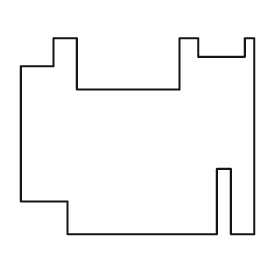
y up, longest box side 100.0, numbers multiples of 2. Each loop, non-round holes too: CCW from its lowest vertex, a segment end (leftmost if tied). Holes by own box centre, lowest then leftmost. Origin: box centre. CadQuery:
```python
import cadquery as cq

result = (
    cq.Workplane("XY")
    .moveTo(-30.0, -42.0)
    .lineTo(34.0, -42.0)
    .lineTo(34.0, -14.0)
    .lineTo(40.0, -14.0)
    .lineTo(40.0, -42.0)
    .lineTo(50.0, -42.0)
    .lineTo(50.0, 42.0)
    .lineTo(46.0, 42.0)
    .lineTo(46.0, 34.0)
    .lineTo(26.0, 34.0)
    .lineTo(26.0, 42.0)
    .lineTo(18.0, 42.0)
    .lineTo(18.0, 20.0)
    .lineTo(-26.0, 20.0)
    .lineTo(-26.0, 42.0)
    .lineTo(-36.0, 42.0)
    .lineTo(-36.0, 30.0)
    .lineTo(-50.0, 30.0)
    .lineTo(-50.0, -28.0)
    .lineTo(-30.0, -28.0)
    .close()
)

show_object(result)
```